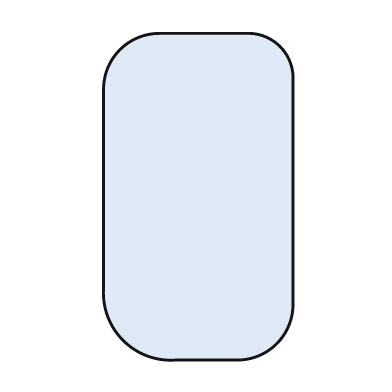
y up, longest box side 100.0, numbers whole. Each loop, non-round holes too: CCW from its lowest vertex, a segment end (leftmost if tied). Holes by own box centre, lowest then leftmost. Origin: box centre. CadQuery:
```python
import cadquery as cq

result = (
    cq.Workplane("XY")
    .moveTo(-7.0, -50.0)
    .lineTo(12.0, -50.0)
    .threePointArc((24.0, -45.0), (29.0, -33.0))
    .lineTo(29.0, 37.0)
    .threePointArc((25.0, 46.0), (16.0, 50.0))
    .lineTo(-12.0, 50.0)
    .threePointArc((-24.0, 45.0), (-29.0, 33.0))
    .lineTo(-29.0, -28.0)
    .threePointArc((-23.0, -44.0), (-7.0, -50.0))
    .close()
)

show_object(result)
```